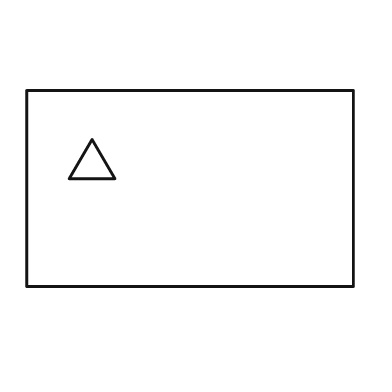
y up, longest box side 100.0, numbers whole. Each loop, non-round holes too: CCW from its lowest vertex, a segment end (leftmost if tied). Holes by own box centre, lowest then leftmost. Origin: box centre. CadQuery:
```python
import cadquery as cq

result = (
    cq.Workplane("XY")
    .moveTo(-50.0, -30.0)
    .lineTo(50.0, -30.0)
    .lineTo(50.0, 30.0)
    .lineTo(-50.0, 30.0)
    .close()
    .moveTo(-37.0, 3.0)
    .lineTo(-23.0, 3.0)
    .lineTo(-30.0, 15.0)
    .close()
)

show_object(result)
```